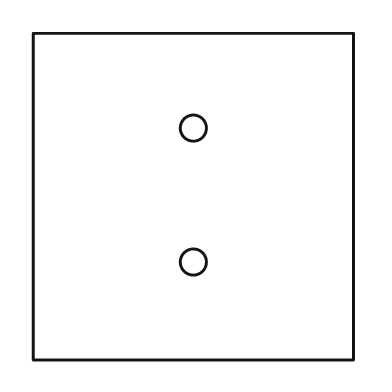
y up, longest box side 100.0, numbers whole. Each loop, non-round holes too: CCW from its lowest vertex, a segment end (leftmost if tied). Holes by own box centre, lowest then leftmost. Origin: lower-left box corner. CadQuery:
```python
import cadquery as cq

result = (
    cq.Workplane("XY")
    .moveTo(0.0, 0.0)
    .lineTo(98.0, 0.0)
    .lineTo(98.0, 100.0)
    .lineTo(0.0, 100.0)
    .close()
    .moveTo(49.0, 30.0)
    .circle(4.0)
    .moveTo(49.0, 71.0)
    .circle(4.0)
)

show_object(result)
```